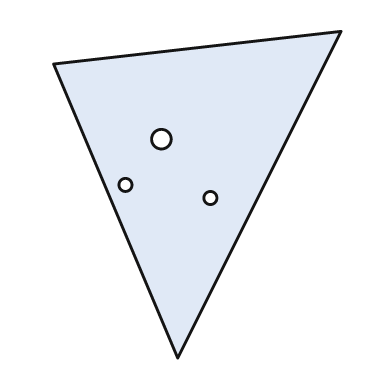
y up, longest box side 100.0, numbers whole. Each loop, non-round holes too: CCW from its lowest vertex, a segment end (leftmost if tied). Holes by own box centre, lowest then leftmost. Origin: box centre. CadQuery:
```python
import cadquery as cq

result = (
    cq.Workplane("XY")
    .moveTo(-6.0, -50.0)
    .lineTo(44.0, 50.0)
    .lineTo(-44.0, 40.0)
    .close()
    .moveTo(4.0, -1.0)
    .circle(2.0)
    .moveTo(-22.0, 3.0)
    .circle(2.0)
    .moveTo(-11.0, 17.0)
    .circle(3.0)
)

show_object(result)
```